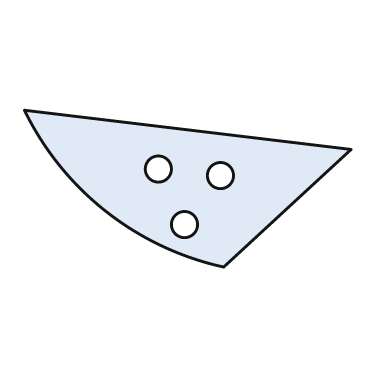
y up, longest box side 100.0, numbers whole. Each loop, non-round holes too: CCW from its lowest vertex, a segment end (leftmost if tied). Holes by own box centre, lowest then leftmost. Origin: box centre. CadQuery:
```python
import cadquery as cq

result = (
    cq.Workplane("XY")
    .moveTo(11.0, -24.0)
    .lineTo(50.0, 12.0)
    .lineTo(-50.0, 24.0)
    .threePointArc((-25.0, -7.0), (11.0, -24.0))
    .close()
    .moveTo(-1.0, -11.0)
    .circle(4.0)
    .moveTo(10.0, 4.0)
    .circle(4.0)
    .moveTo(-9.0, 6.0)
    .circle(4.0)
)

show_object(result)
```